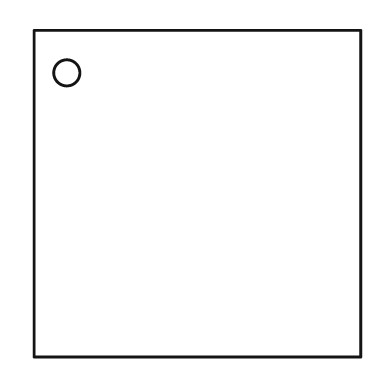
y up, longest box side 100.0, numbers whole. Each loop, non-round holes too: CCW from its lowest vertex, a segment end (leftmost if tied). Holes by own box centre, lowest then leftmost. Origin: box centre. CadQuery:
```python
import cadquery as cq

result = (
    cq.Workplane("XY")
    .moveTo(-50.0, -50.0)
    .lineTo(50.0, -50.0)
    .lineTo(50.0, 50.0)
    .lineTo(-50.0, 50.0)
    .close()
    .moveTo(-40.0, 37.0)
    .circle(4.0)
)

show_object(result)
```